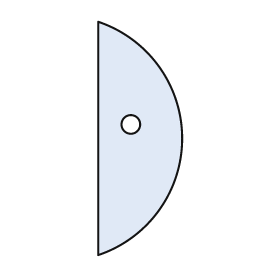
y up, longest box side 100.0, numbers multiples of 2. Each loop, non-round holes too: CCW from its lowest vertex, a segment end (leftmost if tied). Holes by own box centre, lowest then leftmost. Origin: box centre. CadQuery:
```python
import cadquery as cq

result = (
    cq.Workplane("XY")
    .moveTo(-18.0, -50.0)
    .threePointArc((18.0, 0.0), (-18.0, 50.0))
    .close()
    .moveTo(-4.0, 6.0)
    .circle(4.0)
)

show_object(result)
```